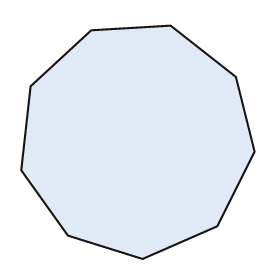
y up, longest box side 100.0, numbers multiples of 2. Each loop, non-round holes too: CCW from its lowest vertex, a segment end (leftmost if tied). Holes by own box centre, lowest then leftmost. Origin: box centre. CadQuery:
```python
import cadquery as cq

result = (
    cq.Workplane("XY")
    .moveTo(2.0, -50.0)
    .lineTo(34.0, -36.0)
    .lineTo(50.0, -4.0)
    .lineTo(42.0, 28.0)
    .lineTo(14.0, 50.0)
    .lineTo(-20.0, 48.0)
    .lineTo(-46.0, 24.0)
    .lineTo(-50.0, -12.0)
    .lineTo(-30.0, -40.0)
    .close()
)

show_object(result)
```